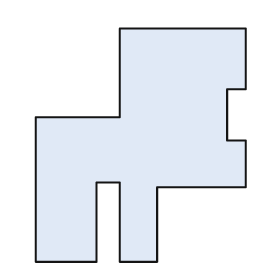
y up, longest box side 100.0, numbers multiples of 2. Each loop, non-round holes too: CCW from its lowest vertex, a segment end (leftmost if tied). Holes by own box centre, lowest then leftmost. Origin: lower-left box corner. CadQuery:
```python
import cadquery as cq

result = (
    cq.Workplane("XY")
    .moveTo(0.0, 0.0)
    .lineTo(26.0, 0.0)
    .lineTo(26.0, 34.0)
    .lineTo(36.0, 34.0)
    .lineTo(36.0, 0.0)
    .lineTo(52.0, 0.0)
    .lineTo(52.0, 32.0)
    .lineTo(90.0, 32.0)
    .lineTo(90.0, 52.0)
    .lineTo(82.0, 52.0)
    .lineTo(82.0, 74.0)
    .lineTo(90.0, 74.0)
    .lineTo(90.0, 100.0)
    .lineTo(36.0, 100.0)
    .lineTo(36.0, 62.0)
    .lineTo(0.0, 62.0)
    .close()
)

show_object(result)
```